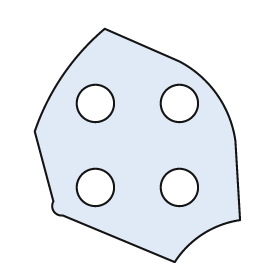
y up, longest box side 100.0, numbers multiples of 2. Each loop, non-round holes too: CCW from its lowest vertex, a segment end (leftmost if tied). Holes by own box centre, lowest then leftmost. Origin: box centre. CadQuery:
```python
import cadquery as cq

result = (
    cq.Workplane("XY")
    .moveTo(16.0, -50.0)
    .threePointArc((28.0, -38.0), (44.0, -32.0))
    .lineTo(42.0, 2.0)
    .threePointArc((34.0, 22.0), (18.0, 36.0))
    .lineTo(-14.0, 50.0)
    .threePointArc((-32.0, 30.0), (-44.0, 6.0))
    .lineTo(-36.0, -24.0)
    .threePointArc((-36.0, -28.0), (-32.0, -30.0))
    .close()
    .moveTo(-18.0, -18.0)
    .circle(8.0)
    .moveTo(18.0, -18.0)
    .circle(8.0)
    .moveTo(-18.0, 18.0)
    .circle(8.0)
    .moveTo(18.0, 18.0)
    .circle(8.0)
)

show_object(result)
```